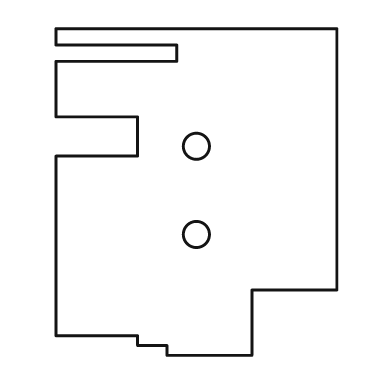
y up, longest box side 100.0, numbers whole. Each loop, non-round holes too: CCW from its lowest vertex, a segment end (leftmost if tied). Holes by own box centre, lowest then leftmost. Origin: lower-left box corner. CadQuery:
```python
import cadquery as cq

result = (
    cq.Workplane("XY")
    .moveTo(34.0, 0.0)
    .lineTo(60.0, 0.0)
    .lineTo(60.0, 20.0)
    .lineTo(86.0, 20.0)
    .lineTo(86.0, 100.0)
    .lineTo(0.0, 100.0)
    .lineTo(0.0, 95.0)
    .lineTo(37.0, 95.0)
    .lineTo(37.0, 90.0)
    .lineTo(0.0, 90.0)
    .lineTo(0.0, 73.0)
    .lineTo(25.0, 73.0)
    .lineTo(25.0, 61.0)
    .lineTo(0.0, 61.0)
    .lineTo(0.0, 6.0)
    .lineTo(25.0, 6.0)
    .lineTo(25.0, 3.0)
    .lineTo(34.0, 3.0)
    .close()
    .moveTo(43.0, 37.0)
    .circle(4.0)
    .moveTo(43.0, 64.0)
    .circle(4.0)
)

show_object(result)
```